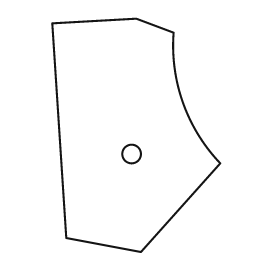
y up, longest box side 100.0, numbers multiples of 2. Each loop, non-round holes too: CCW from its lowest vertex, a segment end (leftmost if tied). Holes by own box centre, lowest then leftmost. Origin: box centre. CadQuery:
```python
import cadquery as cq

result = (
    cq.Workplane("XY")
    .moveTo(2.0, -50.0)
    .lineTo(36.0, -12.0)
    .threePointArc((20.0, 14.0), (16.0, 44.0))
    .lineTo(0.0, 50.0)
    .lineTo(-36.0, 48.0)
    .lineTo(-30.0, -44.0)
    .close()
    .moveTo(-2.0, -8.0)
    .circle(4.0)
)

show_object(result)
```